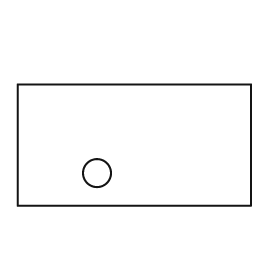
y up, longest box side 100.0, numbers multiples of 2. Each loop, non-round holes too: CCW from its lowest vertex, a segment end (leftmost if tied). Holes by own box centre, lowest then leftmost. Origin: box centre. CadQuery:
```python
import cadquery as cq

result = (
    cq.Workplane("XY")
    .moveTo(-50.0, -26.0)
    .lineTo(50.0, -26.0)
    .lineTo(50.0, 26.0)
    .lineTo(-50.0, 26.0)
    .close()
    .moveTo(-16.0, -12.0)
    .circle(6.0)
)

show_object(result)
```